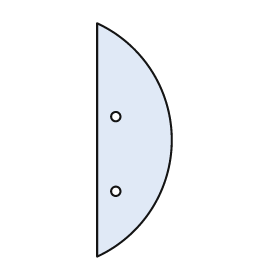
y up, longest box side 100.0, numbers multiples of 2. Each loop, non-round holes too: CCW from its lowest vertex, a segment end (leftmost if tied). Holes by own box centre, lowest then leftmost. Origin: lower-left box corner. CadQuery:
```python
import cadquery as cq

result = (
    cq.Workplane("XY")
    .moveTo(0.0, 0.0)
    .threePointArc((32.0, 50.0), (0.0, 100.0))
    .close()
    .moveTo(8.0, 28.0)
    .circle(2.0)
    .moveTo(8.0, 60.0)
    .circle(2.0)
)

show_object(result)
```